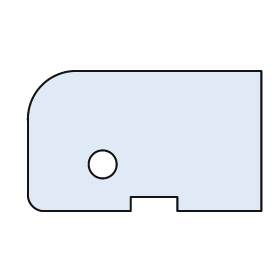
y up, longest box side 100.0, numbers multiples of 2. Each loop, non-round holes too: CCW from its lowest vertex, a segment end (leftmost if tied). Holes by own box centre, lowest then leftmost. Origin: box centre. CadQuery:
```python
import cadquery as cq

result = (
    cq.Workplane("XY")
    .moveTo(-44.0, -30.0)
    .lineTo(-6.0, -30.0)
    .lineTo(-6.0, -24.0)
    .lineTo(14.0, -24.0)
    .lineTo(14.0, -30.0)
    .lineTo(50.0, -30.0)
    .lineTo(50.0, 30.0)
    .lineTo(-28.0, 30.0)
    .threePointArc((-44.0, 24.0), (-50.0, 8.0))
    .lineTo(-50.0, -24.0)
    .threePointArc((-48.0, -28.0), (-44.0, -30.0))
    .close()
    .moveTo(-18.0, -10.0)
    .circle(6.0)
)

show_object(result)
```